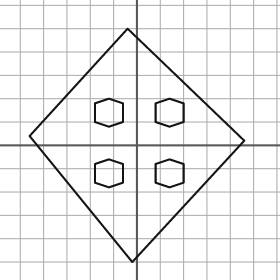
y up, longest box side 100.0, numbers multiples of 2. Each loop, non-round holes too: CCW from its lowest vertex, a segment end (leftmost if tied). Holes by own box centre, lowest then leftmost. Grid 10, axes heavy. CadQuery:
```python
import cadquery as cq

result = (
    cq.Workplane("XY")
    .moveTo(-2.0, -50.0)
    .lineTo(46.0, 2.0)
    .lineTo(-4.0, 50.0)
    .lineTo(-46.0, 4.0)
    .close()
    .moveTo(-12.0, -18.0)
    .lineTo(-6.0, -16.0)
    .lineTo(-6.0, -8.0)
    .lineTo(-12.0, -6.0)
    .lineTo(-18.0, -8.0)
    .lineTo(-18.0, -16.0)
    .close()
    .moveTo(14.0, -18.0)
    .lineTo(20.0, -16.0)
    .lineTo(20.0, -8.0)
    .lineTo(14.0, -6.0)
    .lineTo(8.0, -8.0)
    .lineTo(8.0, -16.0)
    .close()
    .moveTo(-12.0, 8.0)
    .lineTo(-6.0, 10.0)
    .lineTo(-6.0, 18.0)
    .lineTo(-12.0, 20.0)
    .lineTo(-18.0, 18.0)
    .lineTo(-18.0, 10.0)
    .close()
    .moveTo(14.0, 8.0)
    .lineTo(20.0, 10.0)
    .lineTo(20.0, 18.0)
    .lineTo(14.0, 20.0)
    .lineTo(8.0, 18.0)
    .lineTo(8.0, 10.0)
    .close()
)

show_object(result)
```